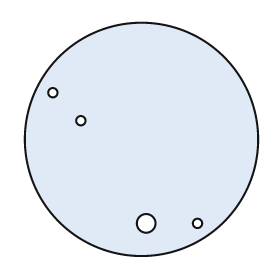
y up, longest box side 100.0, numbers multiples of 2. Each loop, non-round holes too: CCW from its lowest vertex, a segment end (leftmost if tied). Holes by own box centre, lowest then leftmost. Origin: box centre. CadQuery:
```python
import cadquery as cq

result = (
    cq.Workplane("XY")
    .moveTo(0.0, 0.0)
    .circle(50.0)
    .moveTo(2.0, -36.0)
    .circle(4.0)
    .moveTo(24.0, -36.0)
    .circle(2.0)
    .moveTo(-26.0, 8.0)
    .circle(2.0)
    .moveTo(-38.0, 20.0)
    .circle(2.0)
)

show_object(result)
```